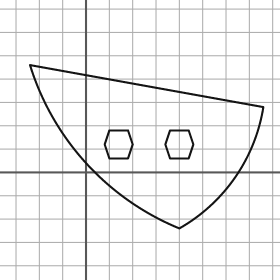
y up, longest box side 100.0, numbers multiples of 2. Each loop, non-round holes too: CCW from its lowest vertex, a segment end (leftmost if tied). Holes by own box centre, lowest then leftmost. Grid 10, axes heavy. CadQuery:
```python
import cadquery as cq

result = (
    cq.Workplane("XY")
    .moveTo(40.0, -24.0)
    .threePointArc((64.0, -2.0), (76.0, 28.0))
    .lineTo(-24.0, 46.0)
    .threePointArc((0.0, 4.0), (40.0, -24.0))
    .close()
    .moveTo(10.0, 6.0)
    .lineTo(18.0, 6.0)
    .lineTo(20.0, 12.0)
    .lineTo(18.0, 18.0)
    .lineTo(10.0, 18.0)
    .lineTo(8.0, 12.0)
    .close()
    .moveTo(36.0, 6.0)
    .lineTo(44.0, 6.0)
    .lineTo(46.0, 12.0)
    .lineTo(44.0, 18.0)
    .lineTo(36.0, 18.0)
    .lineTo(34.0, 12.0)
    .close()
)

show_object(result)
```